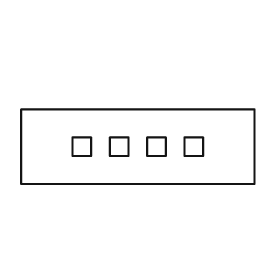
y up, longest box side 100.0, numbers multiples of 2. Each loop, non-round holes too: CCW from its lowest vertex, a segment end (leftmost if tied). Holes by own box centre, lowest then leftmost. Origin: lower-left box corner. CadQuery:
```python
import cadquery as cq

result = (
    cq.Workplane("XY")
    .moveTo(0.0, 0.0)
    .lineTo(100.0, 0.0)
    .lineTo(100.0, 32.0)
    .lineTo(0.0, 32.0)
    .close()
    .moveTo(22.0, 12.0)
    .lineTo(30.0, 12.0)
    .lineTo(30.0, 20.0)
    .lineTo(22.0, 20.0)
    .close()
    .moveTo(38.0, 12.0)
    .lineTo(46.0, 12.0)
    .lineTo(46.0, 20.0)
    .lineTo(38.0, 20.0)
    .close()
    .moveTo(54.0, 12.0)
    .lineTo(62.0, 12.0)
    .lineTo(62.0, 20.0)
    .lineTo(54.0, 20.0)
    .close()
    .moveTo(70.0, 12.0)
    .lineTo(78.0, 12.0)
    .lineTo(78.0, 20.0)
    .lineTo(70.0, 20.0)
    .close()
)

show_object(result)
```